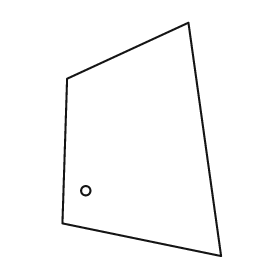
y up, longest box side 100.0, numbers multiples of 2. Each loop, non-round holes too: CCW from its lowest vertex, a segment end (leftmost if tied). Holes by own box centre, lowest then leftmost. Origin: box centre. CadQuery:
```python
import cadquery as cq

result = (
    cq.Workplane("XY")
    .moveTo(34.0, -50.0)
    .lineTo(20.0, 50.0)
    .lineTo(-32.0, 26.0)
    .lineTo(-34.0, -36.0)
    .close()
    .moveTo(-24.0, -22.0)
    .circle(2.0)
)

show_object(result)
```